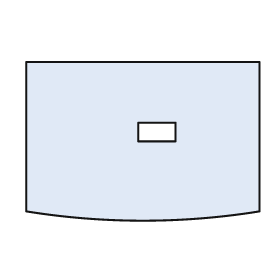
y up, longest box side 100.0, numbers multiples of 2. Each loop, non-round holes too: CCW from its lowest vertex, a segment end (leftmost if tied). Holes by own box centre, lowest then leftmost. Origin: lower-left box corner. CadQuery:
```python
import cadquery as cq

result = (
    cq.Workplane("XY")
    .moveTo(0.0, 4.0)
    .threePointArc((50.0, 0.0), (100.0, 4.0))
    .lineTo(100.0, 68.0)
    .lineTo(0.0, 68.0)
    .close()
    .moveTo(48.0, 34.0)
    .lineTo(64.0, 34.0)
    .lineTo(64.0, 42.0)
    .lineTo(48.0, 42.0)
    .close()
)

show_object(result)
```